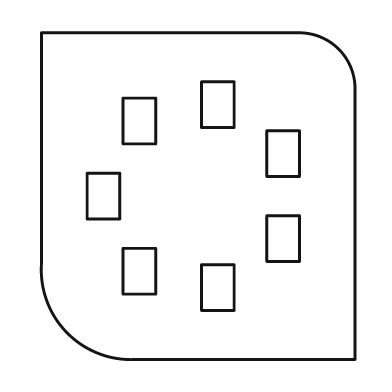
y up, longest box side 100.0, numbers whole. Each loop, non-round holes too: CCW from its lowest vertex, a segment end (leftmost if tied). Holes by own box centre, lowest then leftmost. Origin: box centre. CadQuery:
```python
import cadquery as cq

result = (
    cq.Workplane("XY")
    .moveTo(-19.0, -50.0)
    .lineTo(48.0, -50.0)
    .lineTo(48.0, 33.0)
    .threePointArc((43.0, 45.0), (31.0, 50.0))
    .lineTo(-48.0, 50.0)
    .lineTo(-48.0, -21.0)
    .threePointArc((-40.0, -42.0), (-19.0, -50.0))
    .close()
    .moveTo(1.0, -35.0)
    .lineTo(11.0, -35.0)
    .lineTo(11.0, -21.0)
    .lineTo(1.0, -21.0)
    .close()
    .moveTo(-23.0, -30.0)
    .lineTo(-13.0, -30.0)
    .lineTo(-13.0, -16.0)
    .lineTo(-23.0, -16.0)
    .close()
    .moveTo(21.0, -20.0)
    .lineTo(31.0, -20.0)
    .lineTo(31.0, -6.0)
    .lineTo(21.0, -6.0)
    .close()
    .moveTo(-34.0, -7.0)
    .lineTo(-24.0, -7.0)
    .lineTo(-24.0, 7.0)
    .lineTo(-34.0, 7.0)
    .close()
    .moveTo(21.0, 6.0)
    .lineTo(31.0, 6.0)
    .lineTo(31.0, 20.0)
    .lineTo(21.0, 20.0)
    .close()
    .moveTo(-23.0, 16.0)
    .lineTo(-13.0, 16.0)
    .lineTo(-13.0, 30.0)
    .lineTo(-23.0, 30.0)
    .close()
    .moveTo(1.0, 21.0)
    .lineTo(11.0, 21.0)
    .lineTo(11.0, 35.0)
    .lineTo(1.0, 35.0)
    .close()
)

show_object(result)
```